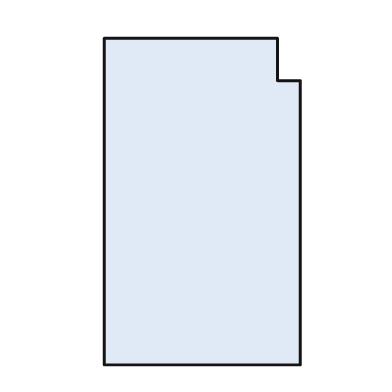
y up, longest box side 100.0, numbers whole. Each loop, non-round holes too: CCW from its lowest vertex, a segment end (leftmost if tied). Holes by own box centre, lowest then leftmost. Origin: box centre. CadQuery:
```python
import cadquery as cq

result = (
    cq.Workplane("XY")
    .moveTo(-30.0, -50.0)
    .lineTo(30.0, -50.0)
    .lineTo(30.0, 37.0)
    .lineTo(23.0, 37.0)
    .lineTo(23.0, 50.0)
    .lineTo(-30.0, 50.0)
    .close()
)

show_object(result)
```